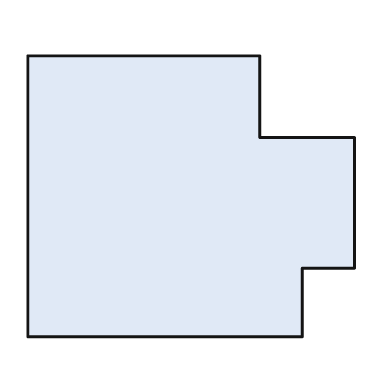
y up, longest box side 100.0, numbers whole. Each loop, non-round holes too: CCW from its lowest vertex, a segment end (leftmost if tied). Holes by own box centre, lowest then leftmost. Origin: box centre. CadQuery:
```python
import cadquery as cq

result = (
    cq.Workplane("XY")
    .moveTo(-50.0, -43.0)
    .lineTo(34.0, -43.0)
    .lineTo(34.0, -22.0)
    .lineTo(50.0, -22.0)
    .lineTo(50.0, 18.0)
    .lineTo(21.0, 18.0)
    .lineTo(21.0, 43.0)
    .lineTo(-50.0, 43.0)
    .close()
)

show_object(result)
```